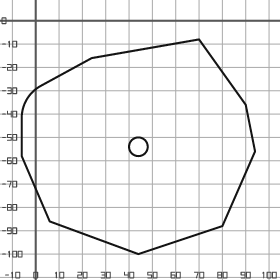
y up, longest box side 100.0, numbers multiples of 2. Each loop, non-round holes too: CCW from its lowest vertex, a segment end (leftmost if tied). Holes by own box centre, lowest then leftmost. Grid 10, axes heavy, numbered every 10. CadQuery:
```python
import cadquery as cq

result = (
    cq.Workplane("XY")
    .moveTo(44.0, -100.0)
    .lineTo(80.0, -88.0)
    .lineTo(94.0, -56.0)
    .lineTo(90.0, -36.0)
    .lineTo(70.0, -8.0)
    .lineTo(24.0, -16.0)
    .lineTo(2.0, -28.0)
    .threePointArc((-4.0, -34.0), (-6.0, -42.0))
    .lineTo(-6.0, -58.0)
    .lineTo(6.0, -86.0)
    .close()
    .moveTo(44.0, -54.0)
    .circle(4.0)
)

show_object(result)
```